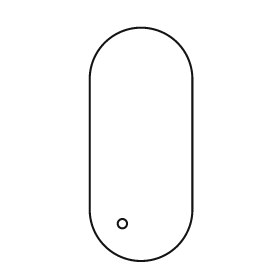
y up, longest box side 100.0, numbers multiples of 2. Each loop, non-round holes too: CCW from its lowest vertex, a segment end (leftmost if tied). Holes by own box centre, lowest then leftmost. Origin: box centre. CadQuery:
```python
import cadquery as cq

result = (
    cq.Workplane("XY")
    .moveTo(-22.0, -28.0)
    .threePointArc((0.0, -50.0), (22.0, -28.0))
    .lineTo(22.0, 28.0)
    .threePointArc((0.0, 50.0), (-22.0, 28.0))
    .close()
    .moveTo(-8.0, -34.0)
    .circle(2.0)
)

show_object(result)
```